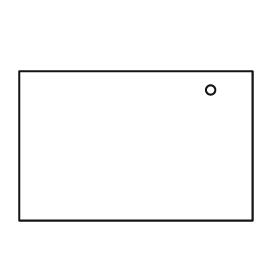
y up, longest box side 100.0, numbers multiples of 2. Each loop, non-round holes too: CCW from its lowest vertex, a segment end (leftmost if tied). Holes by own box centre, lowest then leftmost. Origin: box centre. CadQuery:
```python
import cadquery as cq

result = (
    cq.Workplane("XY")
    .moveTo(-50.0, -32.0)
    .lineTo(50.0, -32.0)
    .lineTo(50.0, 32.0)
    .lineTo(-50.0, 32.0)
    .close()
    .moveTo(32.0, 24.0)
    .circle(2.0)
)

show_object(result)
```